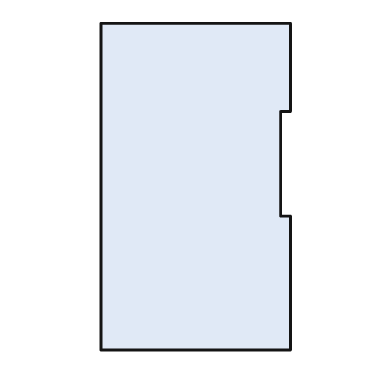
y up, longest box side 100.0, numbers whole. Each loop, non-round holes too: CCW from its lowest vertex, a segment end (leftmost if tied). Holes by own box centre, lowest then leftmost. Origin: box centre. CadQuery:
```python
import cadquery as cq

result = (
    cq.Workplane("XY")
    .moveTo(-29.0, -50.0)
    .lineTo(29.0, -50.0)
    .lineTo(29.0, -9.0)
    .lineTo(26.0, -9.0)
    .lineTo(26.0, 23.0)
    .lineTo(29.0, 23.0)
    .lineTo(29.0, 50.0)
    .lineTo(-29.0, 50.0)
    .close()
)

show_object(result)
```